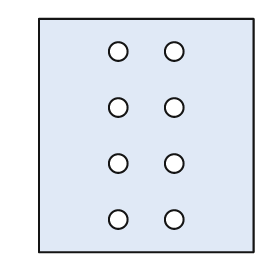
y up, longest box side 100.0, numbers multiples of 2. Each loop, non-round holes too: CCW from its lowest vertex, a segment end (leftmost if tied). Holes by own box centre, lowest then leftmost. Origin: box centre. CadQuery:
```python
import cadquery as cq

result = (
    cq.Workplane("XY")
    .moveTo(-46.0, -50.0)
    .lineTo(46.0, -50.0)
    .lineTo(46.0, 50.0)
    .lineTo(-46.0, 50.0)
    .close()
    .moveTo(-12.0, -36.0)
    .circle(4.0)
    .moveTo(12.0, -36.0)
    .circle(4.0)
    .moveTo(-12.0, -12.0)
    .circle(4.0)
    .moveTo(12.0, -12.0)
    .circle(4.0)
    .moveTo(-12.0, 12.0)
    .circle(4.0)
    .moveTo(12.0, 12.0)
    .circle(4.0)
    .moveTo(-12.0, 36.0)
    .circle(4.0)
    .moveTo(12.0, 36.0)
    .circle(4.0)
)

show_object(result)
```